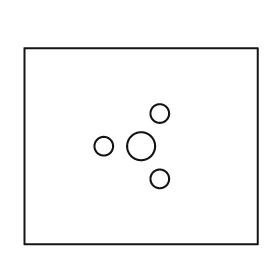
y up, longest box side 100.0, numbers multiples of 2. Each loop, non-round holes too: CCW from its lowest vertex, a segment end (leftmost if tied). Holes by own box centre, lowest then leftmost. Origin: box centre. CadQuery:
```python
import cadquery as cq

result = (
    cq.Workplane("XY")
    .moveTo(-50.0, -42.0)
    .lineTo(50.0, -42.0)
    .lineTo(50.0, 42.0)
    .lineTo(-50.0, 42.0)
    .close()
    .moveTo(8.0, -14.0)
    .circle(4.0)
    .moveTo(-16.0, 0.0)
    .circle(4.0)
    .moveTo(0.0, 0.0)
    .circle(6.0)
    .moveTo(8.0, 14.0)
    .circle(4.0)
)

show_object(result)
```